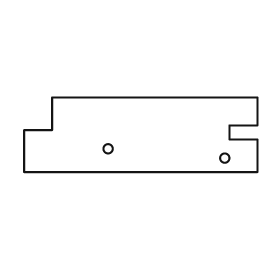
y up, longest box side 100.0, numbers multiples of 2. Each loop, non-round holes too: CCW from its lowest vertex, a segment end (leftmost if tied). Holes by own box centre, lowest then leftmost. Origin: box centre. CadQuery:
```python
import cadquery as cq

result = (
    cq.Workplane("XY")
    .moveTo(-50.0, -16.0)
    .lineTo(50.0, -16.0)
    .lineTo(50.0, -2.0)
    .lineTo(38.0, -2.0)
    .lineTo(38.0, 4.0)
    .lineTo(50.0, 4.0)
    .lineTo(50.0, 16.0)
    .lineTo(-38.0, 16.0)
    .lineTo(-38.0, 2.0)
    .lineTo(-50.0, 2.0)
    .close()
    .moveTo(36.0, -10.0)
    .circle(2.0)
    .moveTo(-14.0, -6.0)
    .circle(2.0)
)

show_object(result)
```